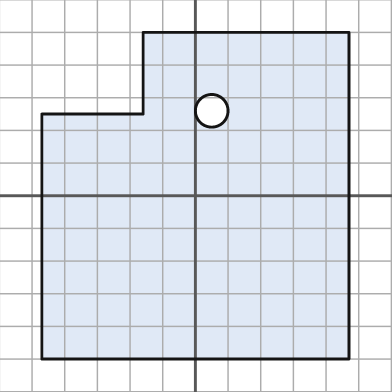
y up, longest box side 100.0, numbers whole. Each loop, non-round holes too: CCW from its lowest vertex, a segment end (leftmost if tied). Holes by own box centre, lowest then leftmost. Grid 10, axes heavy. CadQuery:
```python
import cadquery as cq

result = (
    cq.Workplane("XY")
    .moveTo(-47.0, -50.0)
    .lineTo(47.0, -50.0)
    .lineTo(47.0, 50.0)
    .lineTo(-16.0, 50.0)
    .lineTo(-16.0, 25.0)
    .lineTo(-47.0, 25.0)
    .close()
    .moveTo(5.0, 26.0)
    .circle(5.0)
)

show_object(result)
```